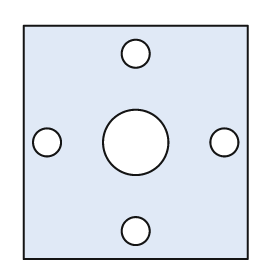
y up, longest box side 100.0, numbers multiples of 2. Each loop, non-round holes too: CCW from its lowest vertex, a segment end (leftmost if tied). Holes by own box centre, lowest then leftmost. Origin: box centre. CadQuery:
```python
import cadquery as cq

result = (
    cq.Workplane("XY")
    .moveTo(-48.0, -50.0)
    .lineTo(48.0, -50.0)
    .lineTo(48.0, 50.0)
    .lineTo(-48.0, 50.0)
    .close()
    .moveTo(0.0, -38.0)
    .circle(6.0)
    .moveTo(-38.0, 0.0)
    .circle(6.0)
    .moveTo(0.0, 0.0)
    .circle(14.0)
    .moveTo(38.0, 0.0)
    .circle(6.0)
    .moveTo(0.0, 38.0)
    .circle(6.0)
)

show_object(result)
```